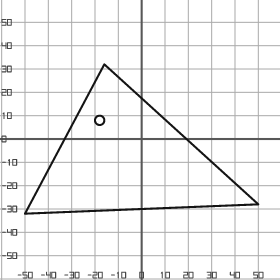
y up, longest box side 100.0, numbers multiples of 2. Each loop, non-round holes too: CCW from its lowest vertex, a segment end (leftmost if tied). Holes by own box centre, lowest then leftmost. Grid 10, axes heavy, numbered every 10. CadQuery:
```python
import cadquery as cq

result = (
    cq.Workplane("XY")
    .moveTo(-50.0, -32.0)
    .lineTo(50.0, -28.0)
    .lineTo(-16.0, 32.0)
    .close()
    .moveTo(-18.0, 8.0)
    .circle(2.0)
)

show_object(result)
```